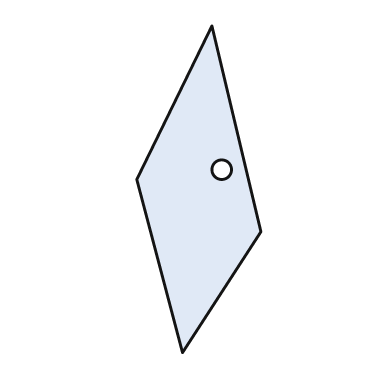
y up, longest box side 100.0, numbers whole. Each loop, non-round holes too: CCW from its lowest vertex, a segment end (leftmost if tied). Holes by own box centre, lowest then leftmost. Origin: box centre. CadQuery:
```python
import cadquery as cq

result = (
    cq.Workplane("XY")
    .moveTo(-5.0, -50.0)
    .lineTo(19.0, -13.0)
    .lineTo(4.0, 50.0)
    .lineTo(-19.0, 3.0)
    .close()
    .moveTo(7.0, 6.0)
    .circle(3.0)
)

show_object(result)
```